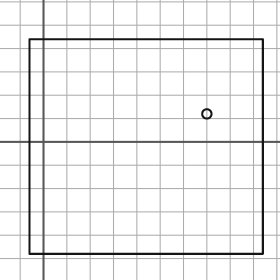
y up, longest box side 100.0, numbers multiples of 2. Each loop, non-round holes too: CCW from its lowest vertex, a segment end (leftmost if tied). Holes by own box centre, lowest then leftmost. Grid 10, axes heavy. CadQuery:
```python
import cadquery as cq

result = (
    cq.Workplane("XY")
    .moveTo(-6.0, -48.0)
    .lineTo(94.0, -48.0)
    .lineTo(94.0, 44.0)
    .lineTo(-6.0, 44.0)
    .close()
    .moveTo(70.0, 12.0)
    .circle(2.0)
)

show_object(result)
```